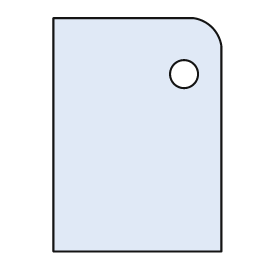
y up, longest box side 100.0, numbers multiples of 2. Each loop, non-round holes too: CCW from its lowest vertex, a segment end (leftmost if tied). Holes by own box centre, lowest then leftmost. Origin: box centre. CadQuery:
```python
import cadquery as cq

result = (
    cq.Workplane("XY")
    .moveTo(-36.0, -50.0)
    .lineTo(36.0, -50.0)
    .lineTo(36.0, 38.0)
    .threePointArc((32.0, 46.0), (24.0, 50.0))
    .lineTo(-36.0, 50.0)
    .close()
    .moveTo(20.0, 26.0)
    .circle(6.0)
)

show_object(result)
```